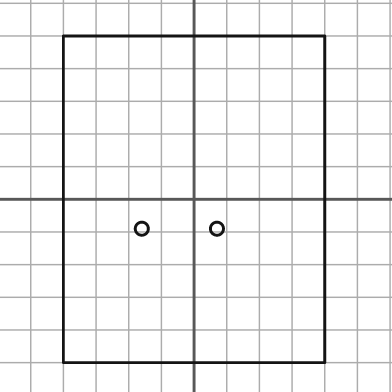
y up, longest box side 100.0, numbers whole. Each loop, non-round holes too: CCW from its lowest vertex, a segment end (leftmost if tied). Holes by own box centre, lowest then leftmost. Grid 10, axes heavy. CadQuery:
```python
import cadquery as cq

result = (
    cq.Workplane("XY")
    .moveTo(-40.0, -50.0)
    .lineTo(40.0, -50.0)
    .lineTo(40.0, 50.0)
    .lineTo(-40.0, 50.0)
    .close()
    .moveTo(-16.0, -9.0)
    .circle(2.0)
    .moveTo(7.0, -9.0)
    .circle(2.0)
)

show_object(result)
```